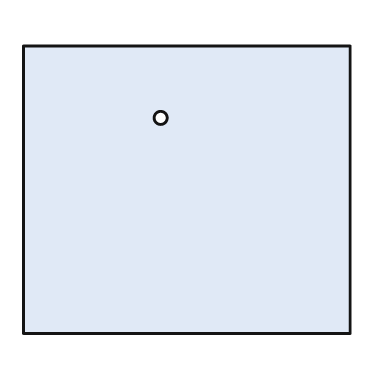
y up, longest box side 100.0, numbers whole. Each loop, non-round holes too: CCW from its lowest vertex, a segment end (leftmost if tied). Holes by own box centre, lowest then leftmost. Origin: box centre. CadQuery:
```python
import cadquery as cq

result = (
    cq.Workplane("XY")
    .moveTo(-50.0, -44.0)
    .lineTo(50.0, -44.0)
    .lineTo(50.0, 44.0)
    .lineTo(-50.0, 44.0)
    .close()
    .moveTo(-8.0, 22.0)
    .circle(2.0)
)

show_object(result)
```